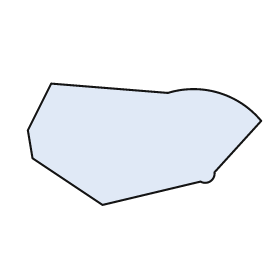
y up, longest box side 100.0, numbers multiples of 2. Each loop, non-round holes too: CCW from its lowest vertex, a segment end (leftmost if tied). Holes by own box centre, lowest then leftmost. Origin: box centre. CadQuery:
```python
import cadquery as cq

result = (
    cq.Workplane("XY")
    .moveTo(-18.0, -26.0)
    .lineTo(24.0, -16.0)
    .threePointArc((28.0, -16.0), (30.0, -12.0))
    .lineTo(50.0, 10.0)
    .threePointArc((32.0, 22.0), (10.0, 22.0))
    .lineTo(-40.0, 26.0)
    .lineTo(-50.0, 6.0)
    .lineTo(-48.0, -6.0)
    .close()
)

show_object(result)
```